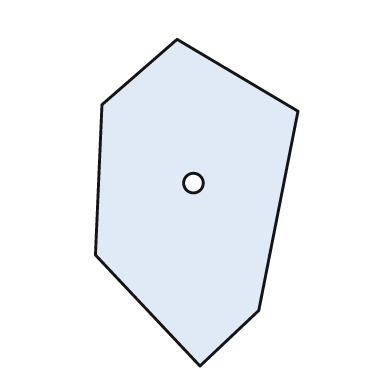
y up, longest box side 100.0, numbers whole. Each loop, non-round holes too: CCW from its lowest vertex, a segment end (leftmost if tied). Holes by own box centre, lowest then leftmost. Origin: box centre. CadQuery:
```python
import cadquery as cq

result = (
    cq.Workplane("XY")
    .moveTo(1.0, -50.0)
    .lineTo(19.0, -33.0)
    .lineTo(31.0, 28.0)
    .lineTo(-6.0, 50.0)
    .lineTo(-29.0, 30.0)
    .lineTo(-31.0, -16.0)
    .close()
    .moveTo(-1.0, 6.0)
    .circle(3.0)
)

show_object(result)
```